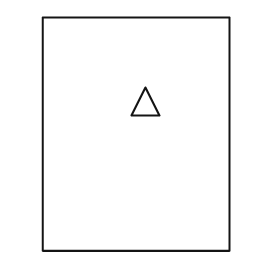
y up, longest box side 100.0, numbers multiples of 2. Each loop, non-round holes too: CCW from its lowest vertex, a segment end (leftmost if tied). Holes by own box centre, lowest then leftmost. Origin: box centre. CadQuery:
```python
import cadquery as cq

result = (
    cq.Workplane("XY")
    .moveTo(-40.0, -50.0)
    .lineTo(40.0, -50.0)
    .lineTo(40.0, 50.0)
    .lineTo(-40.0, 50.0)
    .close()
    .moveTo(-2.0, 8.0)
    .lineTo(10.0, 8.0)
    .lineTo(4.0, 20.0)
    .close()
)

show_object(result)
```